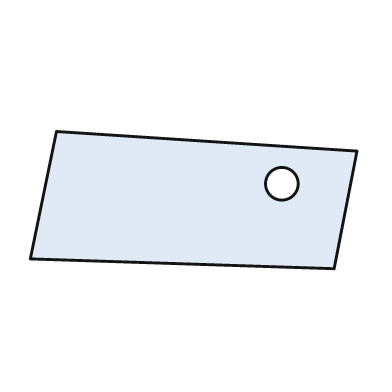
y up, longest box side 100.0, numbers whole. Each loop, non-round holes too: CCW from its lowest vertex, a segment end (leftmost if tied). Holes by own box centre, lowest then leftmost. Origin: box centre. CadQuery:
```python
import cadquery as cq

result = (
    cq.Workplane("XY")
    .moveTo(43.0, -21.0)
    .lineTo(50.0, 15.0)
    .lineTo(-42.0, 21.0)
    .lineTo(-50.0, -18.0)
    .close()
    .moveTo(27.0, 5.0)
    .circle(5.0)
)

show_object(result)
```